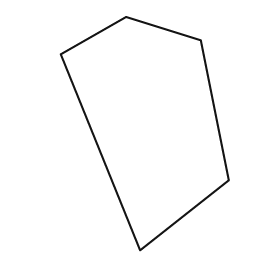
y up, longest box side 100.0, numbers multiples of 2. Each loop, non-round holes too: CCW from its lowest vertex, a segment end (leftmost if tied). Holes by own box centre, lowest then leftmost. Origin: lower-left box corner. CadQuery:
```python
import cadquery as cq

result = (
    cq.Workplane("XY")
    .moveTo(34.0, 0.0)
    .lineTo(72.0, 30.0)
    .lineTo(60.0, 90.0)
    .lineTo(28.0, 100.0)
    .lineTo(0.0, 84.0)
    .close()
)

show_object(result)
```